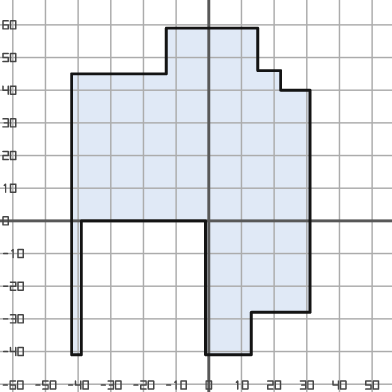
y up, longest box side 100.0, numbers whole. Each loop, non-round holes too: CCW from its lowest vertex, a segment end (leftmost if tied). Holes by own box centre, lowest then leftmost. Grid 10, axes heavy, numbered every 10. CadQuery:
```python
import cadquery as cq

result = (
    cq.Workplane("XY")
    .moveTo(-42.0, -41.0)
    .lineTo(-39.0, -41.0)
    .lineTo(-39.0, 0.0)
    .lineTo(-1.0, 0.0)
    .lineTo(-1.0, -41.0)
    .lineTo(13.0, -41.0)
    .lineTo(13.0, -28.0)
    .lineTo(31.0, -28.0)
    .lineTo(31.0, 40.0)
    .lineTo(22.0, 40.0)
    .lineTo(22.0, 46.0)
    .lineTo(15.0, 46.0)
    .lineTo(15.0, 59.0)
    .lineTo(-13.0, 59.0)
    .lineTo(-13.0, 45.0)
    .lineTo(-42.0, 45.0)
    .close()
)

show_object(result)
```